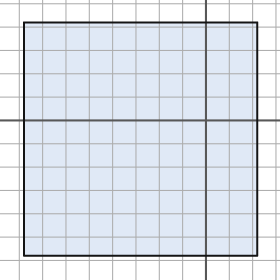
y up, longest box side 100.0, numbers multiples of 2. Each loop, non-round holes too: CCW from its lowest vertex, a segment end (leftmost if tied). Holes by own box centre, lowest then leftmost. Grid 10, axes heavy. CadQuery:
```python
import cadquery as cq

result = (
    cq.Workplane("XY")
    .moveTo(-78.0, -58.0)
    .lineTo(22.0, -58.0)
    .lineTo(22.0, 42.0)
    .lineTo(-78.0, 42.0)
    .close()
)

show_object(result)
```